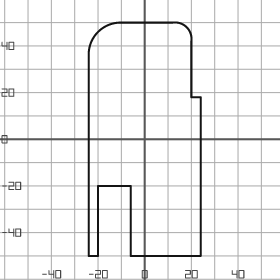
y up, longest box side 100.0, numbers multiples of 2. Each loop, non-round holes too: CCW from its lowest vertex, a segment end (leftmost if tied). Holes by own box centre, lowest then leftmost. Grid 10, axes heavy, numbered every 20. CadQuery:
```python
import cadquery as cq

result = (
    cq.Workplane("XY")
    .moveTo(-24.0, -50.0)
    .lineTo(-20.0, -50.0)
    .lineTo(-20.0, -20.0)
    .lineTo(-6.0, -20.0)
    .lineTo(-6.0, -50.0)
    .lineTo(24.0, -50.0)
    .lineTo(24.0, 18.0)
    .lineTo(20.0, 18.0)
    .lineTo(20.0, 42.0)
    .threePointArc((18.0, 48.0), (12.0, 50.0))
    .lineTo(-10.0, 50.0)
    .threePointArc((-20.0, 46.0), (-24.0, 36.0))
    .close()
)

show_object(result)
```